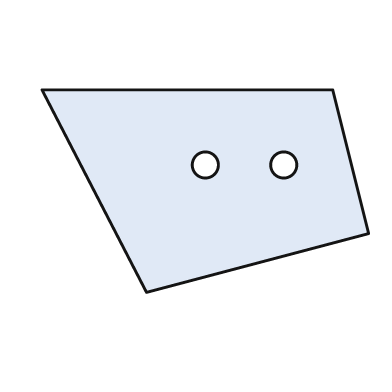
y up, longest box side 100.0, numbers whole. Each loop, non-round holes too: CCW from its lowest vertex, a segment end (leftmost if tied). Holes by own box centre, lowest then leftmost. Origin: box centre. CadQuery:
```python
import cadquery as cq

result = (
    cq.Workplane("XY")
    .moveTo(-18.0, -31.0)
    .lineTo(50.0, -13.0)
    .lineTo(39.0, 31.0)
    .lineTo(-50.0, 31.0)
    .close()
    .moveTo(0.0, 8.0)
    .circle(4.0)
    .moveTo(24.0, 8.0)
    .circle(4.0)
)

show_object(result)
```